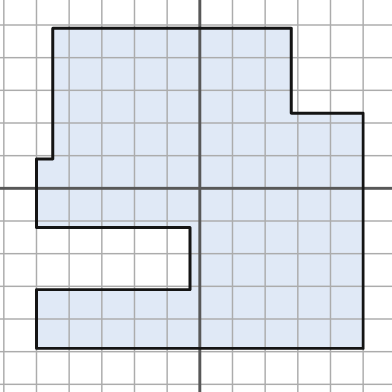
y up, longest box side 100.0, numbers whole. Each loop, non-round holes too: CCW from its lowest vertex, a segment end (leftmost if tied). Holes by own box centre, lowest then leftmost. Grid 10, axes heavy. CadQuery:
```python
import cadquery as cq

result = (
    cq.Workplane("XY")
    .moveTo(-50.0, -49.0)
    .lineTo(50.0, -49.0)
    .lineTo(50.0, 23.0)
    .lineTo(28.0, 23.0)
    .lineTo(28.0, 49.0)
    .lineTo(-45.0, 49.0)
    .lineTo(-45.0, 9.0)
    .lineTo(-50.0, 9.0)
    .lineTo(-50.0, -12.0)
    .lineTo(-3.0, -12.0)
    .lineTo(-3.0, -31.0)
    .lineTo(-50.0, -31.0)
    .close()
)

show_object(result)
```